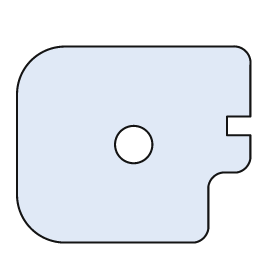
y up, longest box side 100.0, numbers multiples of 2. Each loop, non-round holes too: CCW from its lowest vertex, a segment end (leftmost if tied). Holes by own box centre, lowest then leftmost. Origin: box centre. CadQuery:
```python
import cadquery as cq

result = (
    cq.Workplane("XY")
    .moveTo(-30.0, -42.0)
    .lineTo(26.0, -42.0)
    .threePointArc((30.0, -40.0), (32.0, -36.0))
    .lineTo(32.0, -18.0)
    .threePointArc((34.0, -14.0), (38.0, -12.0))
    .lineTo(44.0, -12.0)
    .threePointArc((48.0, -10.0), (50.0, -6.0))
    .lineTo(50.0, 4.0)
    .lineTo(40.0, 4.0)
    .lineTo(40.0, 12.0)
    .lineTo(50.0, 12.0)
    .lineTo(50.0, 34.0)
    .threePointArc((48.0, 40.0), (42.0, 42.0))
    .lineTo(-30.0, 42.0)
    .threePointArc((-44.0, 36.0), (-50.0, 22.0))
    .lineTo(-50.0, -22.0)
    .threePointArc((-44.0, -36.0), (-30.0, -42.0))
    .close()
    .moveTo(0.0, 0.0)
    .circle(8.0)
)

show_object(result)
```